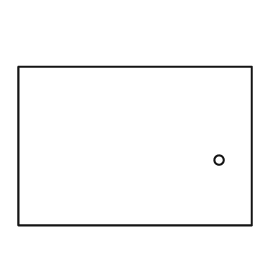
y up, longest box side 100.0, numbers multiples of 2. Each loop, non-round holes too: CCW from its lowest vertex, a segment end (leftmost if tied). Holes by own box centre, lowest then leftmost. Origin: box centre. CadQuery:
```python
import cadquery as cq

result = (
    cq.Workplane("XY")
    .moveTo(-50.0, -34.0)
    .lineTo(50.0, -34.0)
    .lineTo(50.0, 34.0)
    .lineTo(-50.0, 34.0)
    .close()
    .moveTo(36.0, -6.0)
    .circle(2.0)
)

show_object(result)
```